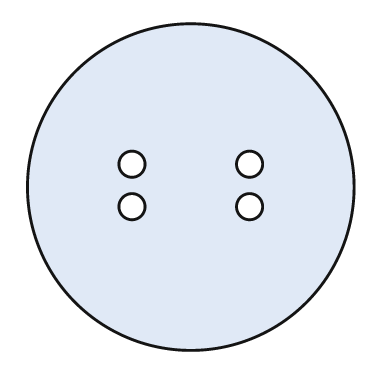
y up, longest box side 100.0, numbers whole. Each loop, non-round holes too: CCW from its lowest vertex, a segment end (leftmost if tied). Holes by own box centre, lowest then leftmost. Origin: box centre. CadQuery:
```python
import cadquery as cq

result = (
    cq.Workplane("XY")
    .moveTo(0.0, 0.0)
    .circle(50.0)
    .moveTo(-18.0, -6.0)
    .circle(4.0)
    .moveTo(18.0, -6.0)
    .circle(4.0)
    .moveTo(-18.0, 7.0)
    .circle(4.0)
    .moveTo(18.0, 7.0)
    .circle(4.0)
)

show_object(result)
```